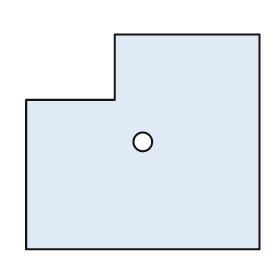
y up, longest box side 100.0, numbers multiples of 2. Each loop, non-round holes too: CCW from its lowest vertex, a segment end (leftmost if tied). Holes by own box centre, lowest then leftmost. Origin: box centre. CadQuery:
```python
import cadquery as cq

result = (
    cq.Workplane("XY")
    .moveTo(-50.0, -46.0)
    .lineTo(50.0, -46.0)
    .lineTo(50.0, 46.0)
    .lineTo(-12.0, 46.0)
    .lineTo(-12.0, 18.0)
    .lineTo(-50.0, 18.0)
    .close()
    .moveTo(0.0, 0.0)
    .circle(4.0)
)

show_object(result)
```